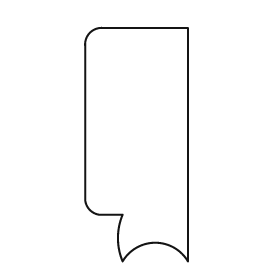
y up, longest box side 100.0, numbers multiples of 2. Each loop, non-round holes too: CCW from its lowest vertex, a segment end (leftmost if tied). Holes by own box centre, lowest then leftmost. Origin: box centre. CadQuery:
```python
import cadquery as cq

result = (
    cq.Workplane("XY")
    .moveTo(-6.0, -50.0)
    .threePointArc((8.0, -42.0), (22.0, -50.0))
    .lineTo(22.0, 50.0)
    .lineTo(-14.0, 50.0)
    .threePointArc((-20.0, 48.0), (-22.0, 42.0))
    .lineTo(-22.0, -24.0)
    .threePointArc((-20.0, -28.0), (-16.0, -30.0))
    .lineTo(-6.0, -30.0)
    .threePointArc((-8.0, -40.0), (-6.0, -50.0))
    .close()
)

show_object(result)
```